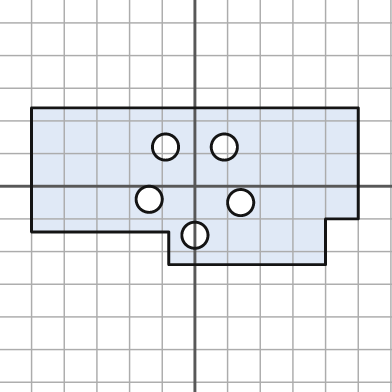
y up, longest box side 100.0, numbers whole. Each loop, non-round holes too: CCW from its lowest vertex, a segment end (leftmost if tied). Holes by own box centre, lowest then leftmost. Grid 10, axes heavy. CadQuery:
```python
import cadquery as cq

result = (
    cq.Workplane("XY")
    .moveTo(-8.0, -24.0)
    .lineTo(40.0, -24.0)
    .lineTo(40.0, -10.0)
    .lineTo(50.0, -10.0)
    .lineTo(50.0, 24.0)
    .lineTo(-50.0, 24.0)
    .lineTo(-50.0, -14.0)
    .lineTo(-8.0, -14.0)
    .close()
    .moveTo(0.0, -15.0)
    .circle(4.0)
    .moveTo(14.0, -5.0)
    .circle(4.0)
    .moveTo(-14.0, -4.0)
    .circle(4.0)
    .moveTo(-9.0, 12.0)
    .circle(4.0)
    .moveTo(9.0, 12.0)
    .circle(4.0)
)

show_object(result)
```